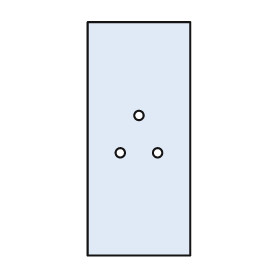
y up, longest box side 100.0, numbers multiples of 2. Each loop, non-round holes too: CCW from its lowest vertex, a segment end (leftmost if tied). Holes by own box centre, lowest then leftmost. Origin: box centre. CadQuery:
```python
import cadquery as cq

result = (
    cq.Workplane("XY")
    .moveTo(-22.0, -50.0)
    .lineTo(22.0, -50.0)
    .lineTo(22.0, 50.0)
    .lineTo(-22.0, 50.0)
    .close()
    .moveTo(-8.0, -6.0)
    .circle(2.0)
    .moveTo(8.0, -6.0)
    .circle(2.0)
    .moveTo(0.0, 10.0)
    .circle(2.0)
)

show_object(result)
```